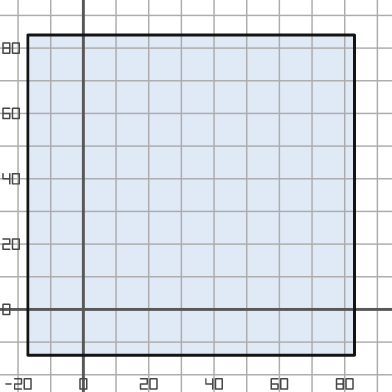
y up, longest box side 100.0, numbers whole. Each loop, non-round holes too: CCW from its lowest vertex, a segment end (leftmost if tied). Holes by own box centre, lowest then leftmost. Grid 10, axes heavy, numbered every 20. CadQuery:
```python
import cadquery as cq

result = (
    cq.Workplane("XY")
    .moveTo(-17.0, -14.0)
    .lineTo(83.0, -14.0)
    .lineTo(83.0, 84.0)
    .lineTo(-17.0, 84.0)
    .close()
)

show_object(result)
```